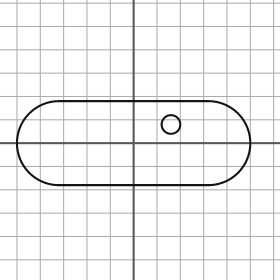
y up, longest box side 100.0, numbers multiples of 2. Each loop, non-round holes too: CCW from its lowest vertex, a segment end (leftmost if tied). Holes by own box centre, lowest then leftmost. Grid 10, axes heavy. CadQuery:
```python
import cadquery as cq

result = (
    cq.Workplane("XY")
    .moveTo(-32.0, -18.0)
    .lineTo(32.0, -18.0)
    .threePointArc((50.0, 0.0), (32.0, 18.0))
    .lineTo(-32.0, 18.0)
    .threePointArc((-50.0, 0.0), (-32.0, -18.0))
    .close()
    .moveTo(16.0, 8.0)
    .circle(4.0)
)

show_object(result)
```